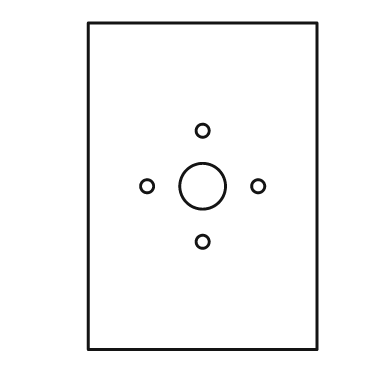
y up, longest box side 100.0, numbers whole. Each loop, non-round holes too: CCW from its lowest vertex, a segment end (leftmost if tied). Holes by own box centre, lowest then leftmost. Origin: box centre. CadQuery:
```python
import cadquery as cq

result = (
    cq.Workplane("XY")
    .moveTo(-35.0, -50.0)
    .lineTo(35.0, -50.0)
    .lineTo(35.0, 50.0)
    .lineTo(-35.0, 50.0)
    .close()
    .moveTo(0.0, -17.0)
    .circle(2.0)
    .moveTo(-17.0, 0.0)
    .circle(2.0)
    .moveTo(0.0, 0.0)
    .circle(7.0)
    .moveTo(17.0, 0.0)
    .circle(2.0)
    .moveTo(0.0, 17.0)
    .circle(2.0)
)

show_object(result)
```